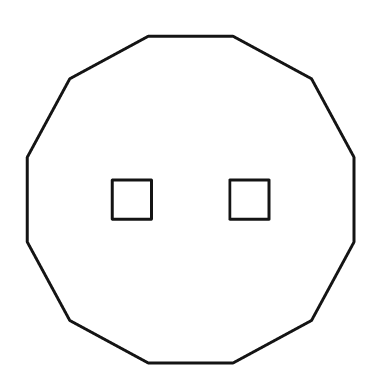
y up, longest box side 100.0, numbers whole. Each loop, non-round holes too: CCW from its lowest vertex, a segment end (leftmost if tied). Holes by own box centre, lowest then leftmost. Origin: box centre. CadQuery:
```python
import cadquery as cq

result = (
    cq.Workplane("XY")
    .moveTo(-13.0, -50.0)
    .lineTo(13.0, -50.0)
    .lineTo(37.0, -37.0)
    .lineTo(50.0, -13.0)
    .lineTo(50.0, 13.0)
    .lineTo(37.0, 37.0)
    .lineTo(13.0, 50.0)
    .lineTo(-13.0, 50.0)
    .lineTo(-37.0, 37.0)
    .lineTo(-50.0, 13.0)
    .lineTo(-50.0, -13.0)
    .lineTo(-37.0, -37.0)
    .close()
    .moveTo(-24.0, -6.0)
    .lineTo(-12.0, -6.0)
    .lineTo(-12.0, 6.0)
    .lineTo(-24.0, 6.0)
    .close()
    .moveTo(12.0, -6.0)
    .lineTo(24.0, -6.0)
    .lineTo(24.0, 6.0)
    .lineTo(12.0, 6.0)
    .close()
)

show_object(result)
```